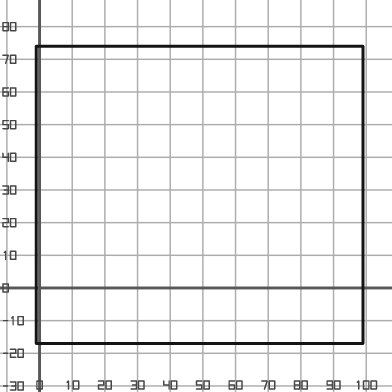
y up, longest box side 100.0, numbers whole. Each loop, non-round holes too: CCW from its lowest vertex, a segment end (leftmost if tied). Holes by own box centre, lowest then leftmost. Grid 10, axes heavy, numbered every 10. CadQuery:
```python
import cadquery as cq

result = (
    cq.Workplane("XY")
    .moveTo(-1.0, -17.0)
    .lineTo(99.0, -17.0)
    .lineTo(99.0, 74.0)
    .lineTo(-1.0, 74.0)
    .close()
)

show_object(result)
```